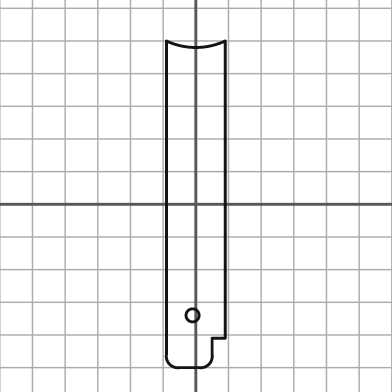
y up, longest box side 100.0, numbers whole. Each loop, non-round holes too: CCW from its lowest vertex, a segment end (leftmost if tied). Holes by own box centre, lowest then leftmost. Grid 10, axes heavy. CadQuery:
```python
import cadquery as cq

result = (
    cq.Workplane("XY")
    .moveTo(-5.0, -50.0)
    .lineTo(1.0, -50.0)
    .threePointArc((4.0, -49.0), (5.0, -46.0))
    .lineTo(5.0, -41.0)
    .lineTo(9.0, -41.0)
    .lineTo(9.0, 50.0)
    .threePointArc((0.0, 48.0), (-9.0, 50.0))
    .lineTo(-9.0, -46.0)
    .threePointArc((-8.0, -49.0), (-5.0, -50.0))
    .close()
    .moveTo(-1.0, -34.0)
    .circle(2.0)
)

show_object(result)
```